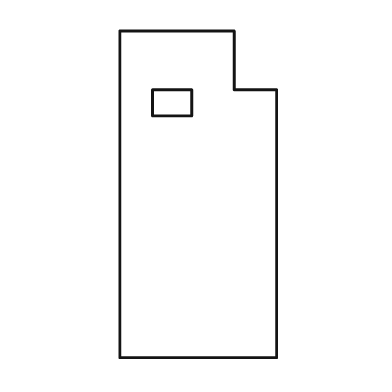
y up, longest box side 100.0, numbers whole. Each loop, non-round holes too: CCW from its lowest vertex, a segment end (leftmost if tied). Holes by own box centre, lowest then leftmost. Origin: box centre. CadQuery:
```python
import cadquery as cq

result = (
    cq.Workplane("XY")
    .moveTo(-24.0, -50.0)
    .lineTo(24.0, -50.0)
    .lineTo(24.0, 32.0)
    .lineTo(11.0, 32.0)
    .lineTo(11.0, 50.0)
    .lineTo(-24.0, 50.0)
    .close()
    .moveTo(-14.0, 24.0)
    .lineTo(-2.0, 24.0)
    .lineTo(-2.0, 32.0)
    .lineTo(-14.0, 32.0)
    .close()
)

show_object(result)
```